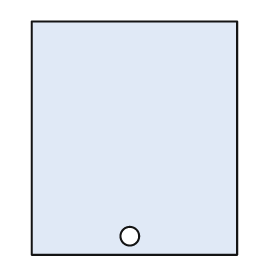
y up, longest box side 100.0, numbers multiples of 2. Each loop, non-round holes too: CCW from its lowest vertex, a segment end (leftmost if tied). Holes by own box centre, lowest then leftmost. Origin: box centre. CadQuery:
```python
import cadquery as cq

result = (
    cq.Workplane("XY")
    .moveTo(-44.0, -50.0)
    .lineTo(44.0, -50.0)
    .lineTo(44.0, 50.0)
    .lineTo(-44.0, 50.0)
    .close()
    .moveTo(-2.0, -42.0)
    .circle(4.0)
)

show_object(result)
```